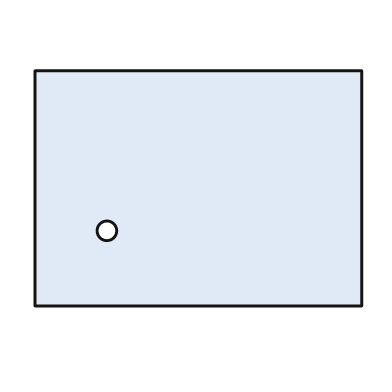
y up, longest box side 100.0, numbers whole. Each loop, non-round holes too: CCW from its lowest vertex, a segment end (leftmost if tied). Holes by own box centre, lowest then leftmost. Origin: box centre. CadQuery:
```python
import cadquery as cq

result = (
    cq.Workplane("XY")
    .moveTo(-50.0, -36.0)
    .lineTo(50.0, -36.0)
    .lineTo(50.0, 36.0)
    .lineTo(-50.0, 36.0)
    .close()
    .moveTo(-28.0, -13.0)
    .circle(3.0)
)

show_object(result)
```